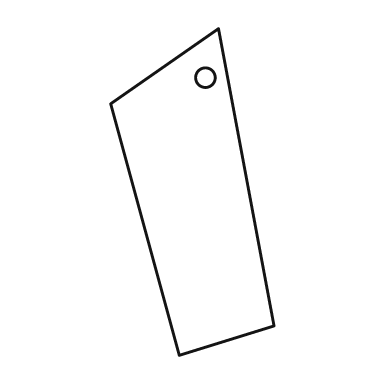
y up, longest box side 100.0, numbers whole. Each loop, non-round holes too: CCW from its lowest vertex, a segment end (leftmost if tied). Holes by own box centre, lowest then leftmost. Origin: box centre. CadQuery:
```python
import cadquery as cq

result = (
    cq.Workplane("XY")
    .moveTo(-4.0, -50.0)
    .lineTo(25.0, -41.0)
    .lineTo(8.0, 50.0)
    .lineTo(-25.0, 27.0)
    .close()
    .moveTo(4.0, 35.0)
    .circle(3.0)
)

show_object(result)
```